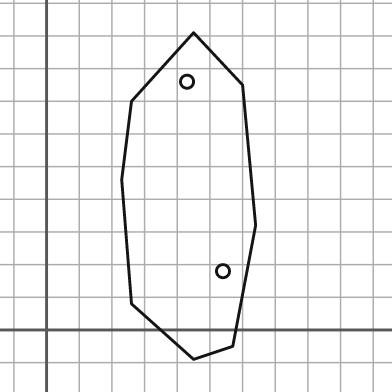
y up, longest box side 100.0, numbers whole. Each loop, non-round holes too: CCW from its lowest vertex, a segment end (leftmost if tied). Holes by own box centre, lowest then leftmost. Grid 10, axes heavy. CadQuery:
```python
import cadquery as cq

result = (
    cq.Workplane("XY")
    .moveTo(45.0, -9.0)
    .lineTo(57.0, -5.0)
    .lineTo(64.0, 32.0)
    .lineTo(60.0, 75.0)
    .lineTo(45.0, 91.0)
    .lineTo(26.0, 70.0)
    .lineTo(23.0, 46.0)
    .lineTo(26.0, 8.0)
    .close()
    .moveTo(54.0, 18.0)
    .circle(2.0)
    .moveTo(43.0, 76.0)
    .circle(2.0)
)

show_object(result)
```